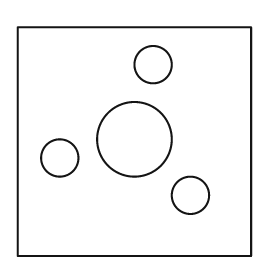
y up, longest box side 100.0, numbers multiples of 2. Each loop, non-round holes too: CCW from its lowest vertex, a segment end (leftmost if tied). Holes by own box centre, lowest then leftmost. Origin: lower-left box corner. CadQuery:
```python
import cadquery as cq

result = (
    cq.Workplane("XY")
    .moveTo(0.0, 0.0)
    .lineTo(100.0, 0.0)
    .lineTo(100.0, 98.0)
    .lineTo(0.0, 98.0)
    .close()
    .moveTo(74.0, 26.0)
    .circle(8.0)
    .moveTo(18.0, 42.0)
    .circle(8.0)
    .moveTo(50.0, 50.0)
    .circle(16.0)
    .moveTo(58.0, 82.0)
    .circle(8.0)
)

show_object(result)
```